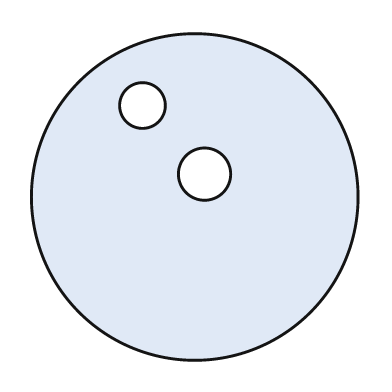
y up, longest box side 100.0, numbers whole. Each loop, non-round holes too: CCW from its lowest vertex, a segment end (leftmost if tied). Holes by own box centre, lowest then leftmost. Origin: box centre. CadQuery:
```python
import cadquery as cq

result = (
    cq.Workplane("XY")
    .moveTo(0.0, 0.0)
    .circle(50.0)
    .moveTo(3.0, 7.0)
    .circle(8.0)
    .moveTo(-16.0, 28.0)
    .circle(7.0)
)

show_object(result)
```